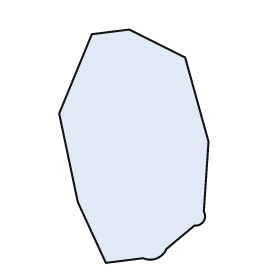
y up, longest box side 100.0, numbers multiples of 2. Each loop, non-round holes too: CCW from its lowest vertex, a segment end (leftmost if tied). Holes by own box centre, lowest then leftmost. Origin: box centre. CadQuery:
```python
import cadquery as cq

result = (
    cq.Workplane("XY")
    .moveTo(-12.0, -50.0)
    .lineTo(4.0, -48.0)
    .threePointArc((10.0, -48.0), (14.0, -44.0))
    .lineTo(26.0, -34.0)
    .threePointArc((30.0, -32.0), (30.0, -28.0))
    .lineTo(32.0, 2.0)
    .lineTo(22.0, 38.0)
    .lineTo(-2.0, 50.0)
    .lineTo(-18.0, 48.0)
    .lineTo(-32.0, 14.0)
    .lineTo(-24.0, -24.0)
    .close()
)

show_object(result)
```